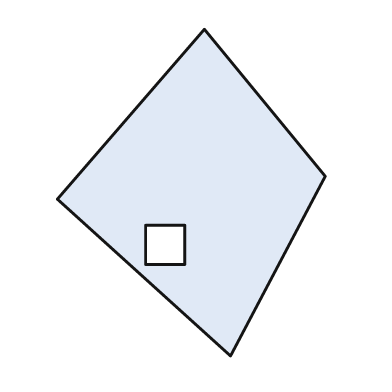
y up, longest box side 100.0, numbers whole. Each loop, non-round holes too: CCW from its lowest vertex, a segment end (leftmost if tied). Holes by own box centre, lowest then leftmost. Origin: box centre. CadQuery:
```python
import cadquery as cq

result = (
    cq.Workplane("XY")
    .moveTo(12.0, -50.0)
    .lineTo(41.0, 5.0)
    .lineTo(4.0, 50.0)
    .lineTo(-41.0, -2.0)
    .close()
    .moveTo(-14.0, -22.0)
    .lineTo(-2.0, -22.0)
    .lineTo(-2.0, -10.0)
    .lineTo(-14.0, -10.0)
    .close()
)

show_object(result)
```